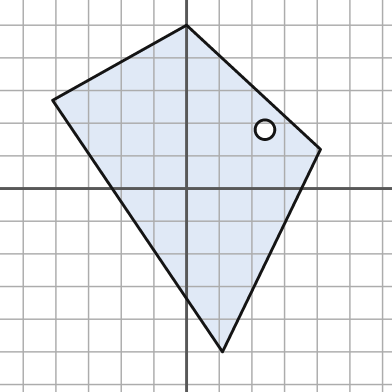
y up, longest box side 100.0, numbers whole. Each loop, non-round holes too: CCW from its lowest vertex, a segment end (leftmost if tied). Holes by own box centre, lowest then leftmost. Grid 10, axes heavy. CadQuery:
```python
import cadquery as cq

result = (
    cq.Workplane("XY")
    .moveTo(11.0, -50.0)
    .lineTo(41.0, 12.0)
    .lineTo(0.0, 50.0)
    .lineTo(-41.0, 27.0)
    .close()
    .moveTo(24.0, 18.0)
    .circle(3.0)
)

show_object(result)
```